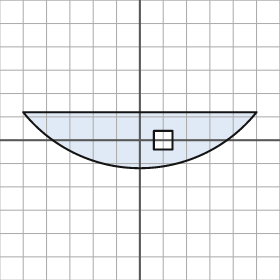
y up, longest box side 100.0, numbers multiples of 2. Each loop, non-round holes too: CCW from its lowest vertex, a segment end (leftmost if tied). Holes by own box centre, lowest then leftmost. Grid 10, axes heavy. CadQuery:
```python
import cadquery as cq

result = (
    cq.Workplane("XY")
    .moveTo(-50.0, 12.0)
    .threePointArc((0.0, -12.0), (50.0, 12.0))
    .close()
    .moveTo(6.0, -4.0)
    .lineTo(14.0, -4.0)
    .lineTo(14.0, 4.0)
    .lineTo(6.0, 4.0)
    .close()
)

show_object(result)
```